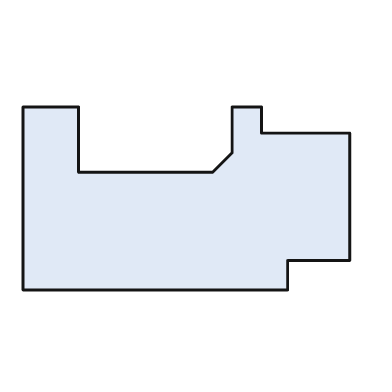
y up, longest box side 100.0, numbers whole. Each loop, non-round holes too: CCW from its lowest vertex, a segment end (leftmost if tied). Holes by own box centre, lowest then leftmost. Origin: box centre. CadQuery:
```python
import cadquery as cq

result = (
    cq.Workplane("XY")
    .moveTo(-50.0, -28.0)
    .lineTo(31.0, -28.0)
    .lineTo(31.0, -19.0)
    .lineTo(50.0, -19.0)
    .lineTo(50.0, 20.0)
    .lineTo(23.0, 20.0)
    .lineTo(23.0, 28.0)
    .lineTo(14.0, 28.0)
    .lineTo(14.0, 14.0)
    .lineTo(8.0, 8.0)
    .lineTo(-33.0, 8.0)
    .lineTo(-33.0, 28.0)
    .lineTo(-50.0, 28.0)
    .close()
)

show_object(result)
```